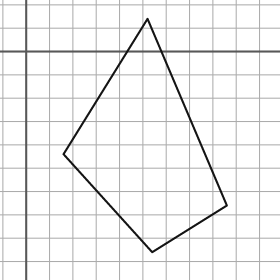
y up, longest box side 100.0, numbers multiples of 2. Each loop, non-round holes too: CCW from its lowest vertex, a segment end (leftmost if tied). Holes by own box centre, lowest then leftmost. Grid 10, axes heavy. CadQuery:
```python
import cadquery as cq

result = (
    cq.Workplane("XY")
    .moveTo(54.0, -86.0)
    .lineTo(86.0, -66.0)
    .lineTo(52.0, 14.0)
    .lineTo(16.0, -44.0)
    .close()
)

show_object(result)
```